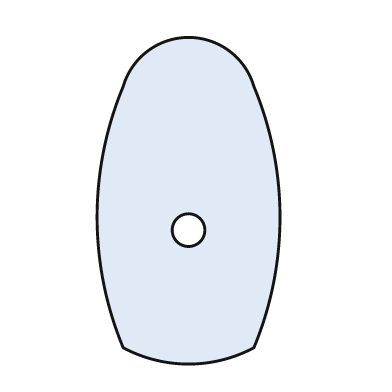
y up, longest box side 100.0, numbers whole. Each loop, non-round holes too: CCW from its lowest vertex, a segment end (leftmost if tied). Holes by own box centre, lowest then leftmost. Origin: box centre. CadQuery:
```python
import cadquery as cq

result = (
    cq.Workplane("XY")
    .moveTo(-20.0, -45.0)
    .threePointArc((0.0, -50.0), (20.0, -45.0))
    .threePointArc((28.0, -5.0), (20.0, 35.0))
    .threePointArc((0.0, 50.0), (-20.0, 35.0))
    .threePointArc((-28.0, -5.0), (-20.0, -45.0))
    .close()
    .moveTo(0.0, -9.0)
    .circle(5.0)
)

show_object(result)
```